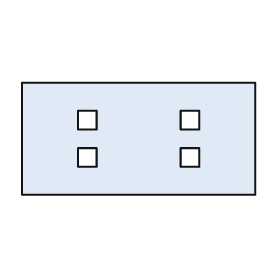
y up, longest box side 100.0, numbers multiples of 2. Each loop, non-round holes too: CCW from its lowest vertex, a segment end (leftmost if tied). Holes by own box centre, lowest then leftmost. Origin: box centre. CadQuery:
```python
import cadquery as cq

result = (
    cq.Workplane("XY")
    .moveTo(-50.0, -24.0)
    .lineTo(50.0, -24.0)
    .lineTo(50.0, 24.0)
    .lineTo(-50.0, 24.0)
    .close()
    .moveTo(-26.0, -12.0)
    .lineTo(-18.0, -12.0)
    .lineTo(-18.0, -4.0)
    .lineTo(-26.0, -4.0)
    .close()
    .moveTo(18.0, -12.0)
    .lineTo(26.0, -12.0)
    .lineTo(26.0, -4.0)
    .lineTo(18.0, -4.0)
    .close()
    .moveTo(-26.0, 4.0)
    .lineTo(-18.0, 4.0)
    .lineTo(-18.0, 12.0)
    .lineTo(-26.0, 12.0)
    .close()
    .moveTo(18.0, 4.0)
    .lineTo(26.0, 4.0)
    .lineTo(26.0, 12.0)
    .lineTo(18.0, 12.0)
    .close()
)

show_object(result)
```